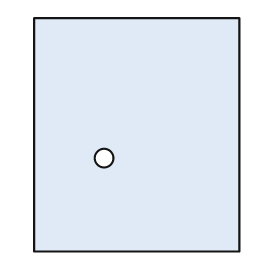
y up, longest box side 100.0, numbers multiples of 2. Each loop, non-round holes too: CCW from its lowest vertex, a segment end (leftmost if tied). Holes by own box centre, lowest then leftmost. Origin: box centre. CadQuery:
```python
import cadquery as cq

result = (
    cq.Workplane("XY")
    .moveTo(-44.0, -50.0)
    .lineTo(44.0, -50.0)
    .lineTo(44.0, 50.0)
    .lineTo(-44.0, 50.0)
    .close()
    .moveTo(-14.0, -10.0)
    .circle(4.0)
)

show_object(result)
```